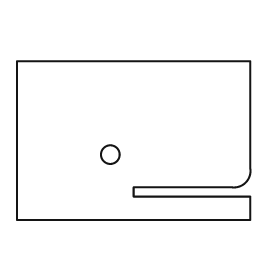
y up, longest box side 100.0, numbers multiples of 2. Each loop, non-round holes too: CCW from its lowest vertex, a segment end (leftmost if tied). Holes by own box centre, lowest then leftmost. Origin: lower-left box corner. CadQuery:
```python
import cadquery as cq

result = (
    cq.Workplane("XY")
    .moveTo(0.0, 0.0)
    .lineTo(100.0, 0.0)
    .lineTo(100.0, 10.0)
    .lineTo(50.0, 10.0)
    .lineTo(50.0, 14.0)
    .lineTo(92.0, 14.0)
    .threePointArc((98.0, 16.0), (100.0, 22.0))
    .lineTo(100.0, 68.0)
    .lineTo(0.0, 68.0)
    .close()
    .moveTo(40.0, 28.0)
    .circle(4.0)
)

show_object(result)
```